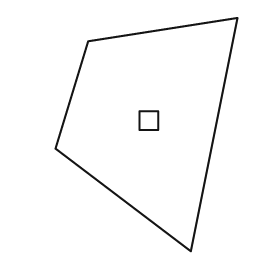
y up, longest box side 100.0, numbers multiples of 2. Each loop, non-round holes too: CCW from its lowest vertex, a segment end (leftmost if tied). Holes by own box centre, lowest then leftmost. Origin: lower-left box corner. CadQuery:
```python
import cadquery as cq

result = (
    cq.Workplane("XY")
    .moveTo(58.0, 0.0)
    .lineTo(78.0, 100.0)
    .lineTo(14.0, 90.0)
    .lineTo(0.0, 44.0)
    .close()
    .moveTo(36.0, 52.0)
    .lineTo(44.0, 52.0)
    .lineTo(44.0, 60.0)
    .lineTo(36.0, 60.0)
    .close()
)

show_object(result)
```